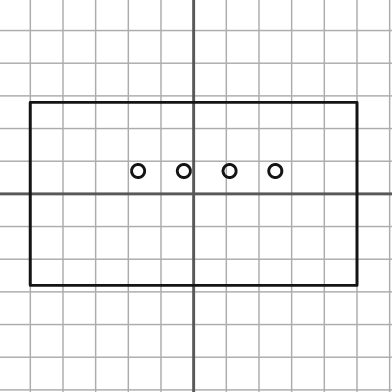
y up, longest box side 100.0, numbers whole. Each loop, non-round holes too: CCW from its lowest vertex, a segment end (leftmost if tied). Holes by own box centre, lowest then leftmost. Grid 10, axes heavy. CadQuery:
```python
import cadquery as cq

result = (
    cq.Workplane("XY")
    .moveTo(-50.0, -28.0)
    .lineTo(50.0, -28.0)
    .lineTo(50.0, 28.0)
    .lineTo(-50.0, 28.0)
    .close()
    .moveTo(-17.0, 7.0)
    .circle(2.0)
    .moveTo(-3.0, 7.0)
    .circle(2.0)
    .moveTo(11.0, 7.0)
    .circle(2.0)
    .moveTo(25.0, 7.0)
    .circle(2.0)
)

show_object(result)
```